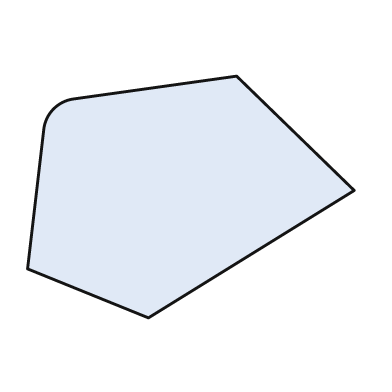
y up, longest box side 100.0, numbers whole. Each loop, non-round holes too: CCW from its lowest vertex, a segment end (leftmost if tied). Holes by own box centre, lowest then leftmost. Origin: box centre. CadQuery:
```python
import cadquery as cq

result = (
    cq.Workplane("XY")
    .moveTo(-13.0, -37.0)
    .lineTo(50.0, 2.0)
    .lineTo(14.0, 37.0)
    .lineTo(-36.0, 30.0)
    .threePointArc((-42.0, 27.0), (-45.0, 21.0))
    .lineTo(-50.0, -22.0)
    .close()
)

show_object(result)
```